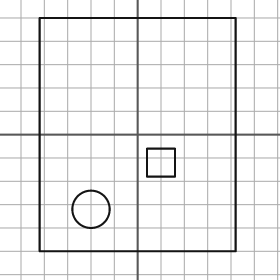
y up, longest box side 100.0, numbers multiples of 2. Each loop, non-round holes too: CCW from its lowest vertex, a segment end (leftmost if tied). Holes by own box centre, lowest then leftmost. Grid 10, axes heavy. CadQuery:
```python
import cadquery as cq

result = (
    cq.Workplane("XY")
    .moveTo(-42.0, -50.0)
    .lineTo(42.0, -50.0)
    .lineTo(42.0, 50.0)
    .lineTo(-42.0, 50.0)
    .close()
    .moveTo(-20.0, -32.0)
    .circle(8.0)
    .moveTo(4.0, -18.0)
    .lineTo(16.0, -18.0)
    .lineTo(16.0, -6.0)
    .lineTo(4.0, -6.0)
    .close()
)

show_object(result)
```